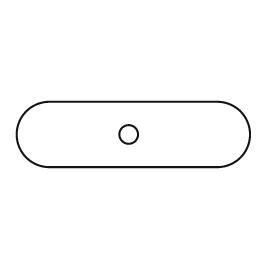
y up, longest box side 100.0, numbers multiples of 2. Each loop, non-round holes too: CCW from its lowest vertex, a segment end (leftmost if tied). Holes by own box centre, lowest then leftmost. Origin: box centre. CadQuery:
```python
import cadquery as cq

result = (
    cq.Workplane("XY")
    .moveTo(-36.0, -14.0)
    .lineTo(36.0, -14.0)
    .threePointArc((50.0, 0.0), (36.0, 14.0))
    .lineTo(-36.0, 14.0)
    .threePointArc((-50.0, 0.0), (-36.0, -14.0))
    .close()
    .moveTo(-2.0, 0.0)
    .circle(4.0)
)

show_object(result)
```